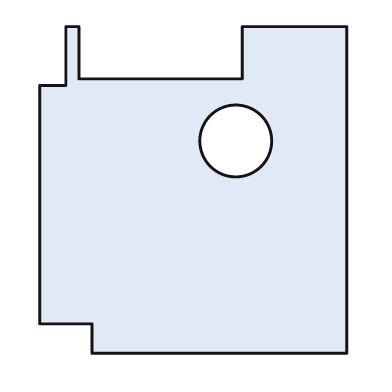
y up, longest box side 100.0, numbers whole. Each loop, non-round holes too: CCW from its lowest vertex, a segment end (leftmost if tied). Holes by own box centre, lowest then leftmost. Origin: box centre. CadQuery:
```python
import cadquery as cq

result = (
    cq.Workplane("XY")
    .moveTo(-31.0, -50.0)
    .lineTo(47.0, -50.0)
    .lineTo(47.0, 50.0)
    .lineTo(15.0, 50.0)
    .lineTo(15.0, 34.0)
    .lineTo(-35.0, 34.0)
    .lineTo(-35.0, 50.0)
    .lineTo(-39.0, 50.0)
    .lineTo(-39.0, 32.0)
    .lineTo(-47.0, 32.0)
    .lineTo(-47.0, -41.0)
    .lineTo(-31.0, -41.0)
    .close()
    .moveTo(13.0, 15.0)
    .circle(11.0)
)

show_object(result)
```